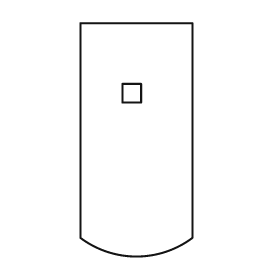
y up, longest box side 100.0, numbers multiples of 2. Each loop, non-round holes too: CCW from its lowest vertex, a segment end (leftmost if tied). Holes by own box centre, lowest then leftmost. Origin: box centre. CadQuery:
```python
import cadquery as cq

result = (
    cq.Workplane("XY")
    .moveTo(-24.0, -42.0)
    .threePointArc((0.0, -50.0), (24.0, -42.0))
    .lineTo(24.0, 50.0)
    .lineTo(-24.0, 50.0)
    .close()
    .moveTo(-6.0, 16.0)
    .lineTo(2.0, 16.0)
    .lineTo(2.0, 24.0)
    .lineTo(-6.0, 24.0)
    .close()
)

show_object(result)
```